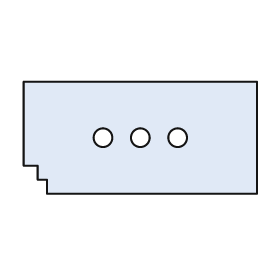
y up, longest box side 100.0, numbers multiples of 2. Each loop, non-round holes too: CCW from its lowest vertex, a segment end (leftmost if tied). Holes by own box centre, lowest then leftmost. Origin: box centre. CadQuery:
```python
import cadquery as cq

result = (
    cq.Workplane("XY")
    .moveTo(-40.0, -24.0)
    .lineTo(50.0, -24.0)
    .lineTo(50.0, 24.0)
    .lineTo(-50.0, 24.0)
    .lineTo(-50.0, -12.0)
    .lineTo(-44.0, -12.0)
    .lineTo(-44.0, -18.0)
    .lineTo(-40.0, -18.0)
    .close()
    .moveTo(-16.0, 0.0)
    .circle(4.0)
    .moveTo(0.0, 0.0)
    .circle(4.0)
    .moveTo(16.0, 0.0)
    .circle(4.0)
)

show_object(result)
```